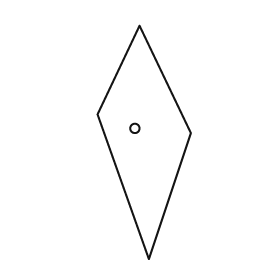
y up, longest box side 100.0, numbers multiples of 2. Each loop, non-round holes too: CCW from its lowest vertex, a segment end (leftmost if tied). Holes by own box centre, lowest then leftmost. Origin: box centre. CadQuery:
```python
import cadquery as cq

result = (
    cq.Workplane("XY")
    .moveTo(2.0, -50.0)
    .lineTo(20.0, 4.0)
    .lineTo(-2.0, 50.0)
    .lineTo(-20.0, 12.0)
    .close()
    .moveTo(-4.0, 6.0)
    .circle(2.0)
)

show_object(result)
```